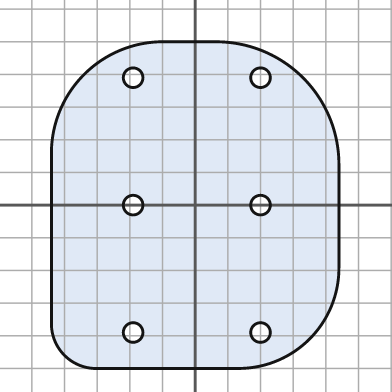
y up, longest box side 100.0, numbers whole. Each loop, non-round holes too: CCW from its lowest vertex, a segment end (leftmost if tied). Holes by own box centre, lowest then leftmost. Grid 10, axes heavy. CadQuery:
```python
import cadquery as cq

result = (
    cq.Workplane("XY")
    .moveTo(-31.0, -50.0)
    .lineTo(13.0, -50.0)
    .threePointArc((35.0, -41.0), (44.0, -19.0))
    .lineTo(44.0, 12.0)
    .threePointArc((33.0, 39.0), (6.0, 50.0))
    .lineTo(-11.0, 50.0)
    .threePointArc((-34.0, 40.0), (-44.0, 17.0))
    .lineTo(-44.0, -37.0)
    .threePointArc((-40.0, -46.0), (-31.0, -50.0))
    .close()
    .moveTo(-19.0, -39.0)
    .circle(3.0)
    .moveTo(20.0, -39.0)
    .circle(3.0)
    .moveTo(-19.0, 0.0)
    .circle(3.0)
    .moveTo(20.0, 0.0)
    .circle(3.0)
    .moveTo(-19.0, 39.0)
    .circle(3.0)
    .moveTo(20.0, 39.0)
    .circle(3.0)
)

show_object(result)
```